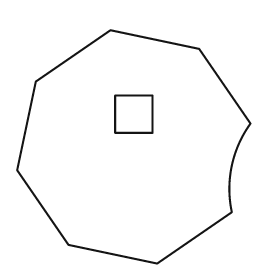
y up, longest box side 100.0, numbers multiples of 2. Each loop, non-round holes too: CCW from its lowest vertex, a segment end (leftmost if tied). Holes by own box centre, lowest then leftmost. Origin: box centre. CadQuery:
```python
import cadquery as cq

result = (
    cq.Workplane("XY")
    .moveTo(10.0, -50.0)
    .lineTo(42.0, -28.0)
    .threePointArc((42.0, -8.0), (50.0, 10.0))
    .lineTo(28.0, 42.0)
    .lineTo(-10.0, 50.0)
    .lineTo(-42.0, 28.0)
    .lineTo(-50.0, -10.0)
    .lineTo(-28.0, -42.0)
    .close()
    .moveTo(-8.0, 6.0)
    .lineTo(8.0, 6.0)
    .lineTo(8.0, 22.0)
    .lineTo(-8.0, 22.0)
    .close()
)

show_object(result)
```